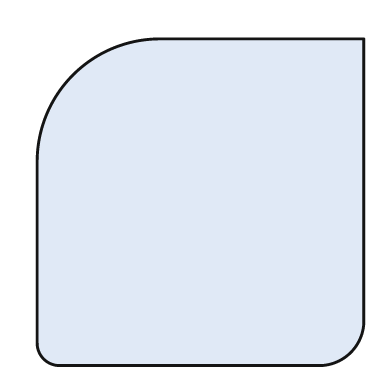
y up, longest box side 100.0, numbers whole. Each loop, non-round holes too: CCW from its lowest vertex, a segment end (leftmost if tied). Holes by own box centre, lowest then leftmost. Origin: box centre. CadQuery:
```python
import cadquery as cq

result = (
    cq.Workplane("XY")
    .moveTo(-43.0, -50.0)
    .lineTo(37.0, -50.0)
    .threePointArc((46.0, -46.0), (50.0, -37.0))
    .lineTo(50.0, 50.0)
    .lineTo(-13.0, 50.0)
    .threePointArc((-39.0, 39.0), (-50.0, 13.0))
    .lineTo(-50.0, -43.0)
    .threePointArc((-48.0, -48.0), (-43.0, -50.0))
    .close()
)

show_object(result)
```